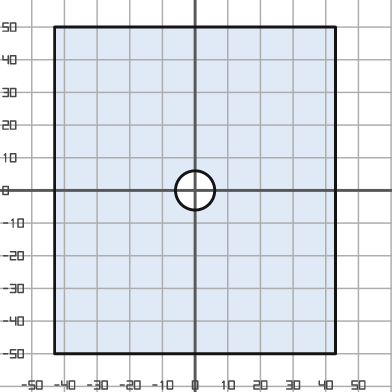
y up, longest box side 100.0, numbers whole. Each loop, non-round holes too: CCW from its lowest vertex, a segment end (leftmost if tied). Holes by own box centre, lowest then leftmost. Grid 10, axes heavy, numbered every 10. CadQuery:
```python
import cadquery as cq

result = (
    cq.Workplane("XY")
    .moveTo(-43.0, -50.0)
    .lineTo(43.0, -50.0)
    .lineTo(43.0, 50.0)
    .lineTo(-43.0, 50.0)
    .close()
    .moveTo(0.0, 0.0)
    .circle(6.0)
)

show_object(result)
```